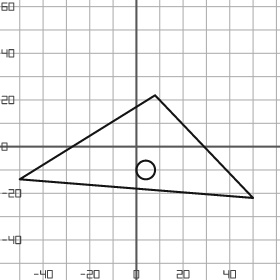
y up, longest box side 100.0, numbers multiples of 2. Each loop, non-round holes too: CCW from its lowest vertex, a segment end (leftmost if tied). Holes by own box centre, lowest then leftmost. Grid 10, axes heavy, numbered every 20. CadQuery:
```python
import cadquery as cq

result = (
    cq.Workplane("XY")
    .moveTo(50.0, -22.0)
    .lineTo(8.0, 22.0)
    .lineTo(-50.0, -14.0)
    .close()
    .moveTo(4.0, -10.0)
    .circle(4.0)
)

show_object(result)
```